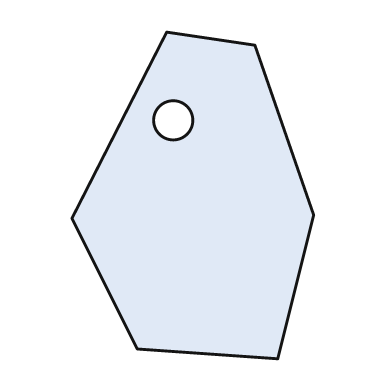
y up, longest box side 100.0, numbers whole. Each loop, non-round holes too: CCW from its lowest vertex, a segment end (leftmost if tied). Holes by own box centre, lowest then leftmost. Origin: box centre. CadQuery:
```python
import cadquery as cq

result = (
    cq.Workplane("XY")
    .moveTo(26.0, -50.0)
    .lineTo(37.0, -6.0)
    .lineTo(19.0, 46.0)
    .lineTo(-8.0, 50.0)
    .lineTo(-37.0, -7.0)
    .lineTo(-17.0, -47.0)
    .close()
    .moveTo(-6.0, 23.0)
    .circle(6.0)
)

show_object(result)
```